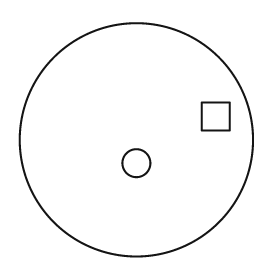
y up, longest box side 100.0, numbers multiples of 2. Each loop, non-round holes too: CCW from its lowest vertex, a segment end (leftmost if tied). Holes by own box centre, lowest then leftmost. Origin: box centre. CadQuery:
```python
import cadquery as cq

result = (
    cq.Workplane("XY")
    .moveTo(0.0, 0.0)
    .circle(50.0)
    .moveTo(0.0, -10.0)
    .circle(6.0)
    .moveTo(28.0, 4.0)
    .lineTo(40.0, 4.0)
    .lineTo(40.0, 16.0)
    .lineTo(28.0, 16.0)
    .close()
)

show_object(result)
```